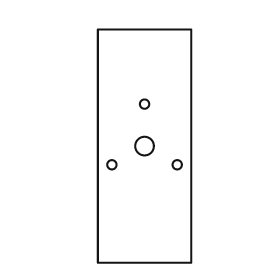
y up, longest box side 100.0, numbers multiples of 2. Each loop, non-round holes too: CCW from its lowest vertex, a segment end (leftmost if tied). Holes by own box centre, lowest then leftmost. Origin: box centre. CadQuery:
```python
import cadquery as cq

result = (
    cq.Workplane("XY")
    .moveTo(-20.0, -50.0)
    .lineTo(20.0, -50.0)
    .lineTo(20.0, 50.0)
    .lineTo(-20.0, 50.0)
    .close()
    .moveTo(-14.0, -8.0)
    .circle(2.0)
    .moveTo(14.0, -8.0)
    .circle(2.0)
    .moveTo(0.0, 0.0)
    .circle(4.0)
    .moveTo(0.0, 18.0)
    .circle(2.0)
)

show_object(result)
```